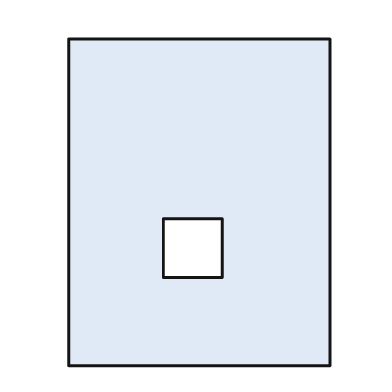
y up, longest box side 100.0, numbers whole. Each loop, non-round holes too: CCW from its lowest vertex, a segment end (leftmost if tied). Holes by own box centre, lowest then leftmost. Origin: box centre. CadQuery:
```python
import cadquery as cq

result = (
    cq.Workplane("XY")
    .moveTo(-40.0, -50.0)
    .lineTo(40.0, -50.0)
    .lineTo(40.0, 50.0)
    .lineTo(-40.0, 50.0)
    .close()
    .moveTo(-11.0, -23.0)
    .lineTo(7.0, -23.0)
    .lineTo(7.0, -5.0)
    .lineTo(-11.0, -5.0)
    .close()
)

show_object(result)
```